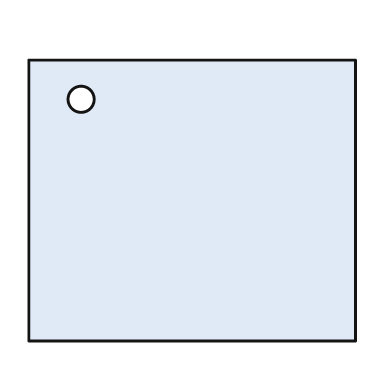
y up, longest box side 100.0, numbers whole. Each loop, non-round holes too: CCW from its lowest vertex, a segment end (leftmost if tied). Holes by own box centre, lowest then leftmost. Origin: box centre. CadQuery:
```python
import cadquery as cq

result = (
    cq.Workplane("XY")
    .moveTo(-50.0, -43.0)
    .lineTo(50.0, -43.0)
    .lineTo(50.0, 43.0)
    .lineTo(-50.0, 43.0)
    .close()
    .moveTo(-34.0, 31.0)
    .circle(4.0)
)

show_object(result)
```